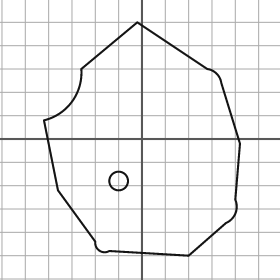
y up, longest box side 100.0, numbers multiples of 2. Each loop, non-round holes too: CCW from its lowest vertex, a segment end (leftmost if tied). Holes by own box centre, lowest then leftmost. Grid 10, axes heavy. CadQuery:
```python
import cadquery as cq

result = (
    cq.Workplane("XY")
    .moveTo(20.0, -50.0)
    .lineTo(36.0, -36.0)
    .threePointArc((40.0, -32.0), (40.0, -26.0))
    .lineTo(42.0, -2.0)
    .lineTo(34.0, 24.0)
    .threePointArc((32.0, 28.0), (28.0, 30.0))
    .lineTo(-2.0, 50.0)
    .lineTo(-26.0, 30.0)
    .threePointArc((-30.0, 16.0), (-42.0, 8.0))
    .lineTo(-36.0, -22.0)
    .lineTo(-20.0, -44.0)
    .threePointArc((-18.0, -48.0), (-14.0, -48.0))
    .close()
    .moveTo(-10.0, -18.0)
    .circle(4.0)
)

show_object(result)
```